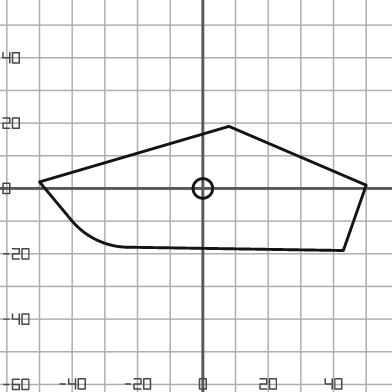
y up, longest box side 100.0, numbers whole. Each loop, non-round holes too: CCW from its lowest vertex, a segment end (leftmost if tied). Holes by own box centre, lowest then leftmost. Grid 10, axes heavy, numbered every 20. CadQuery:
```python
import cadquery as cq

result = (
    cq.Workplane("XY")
    .moveTo(43.0, -19.0)
    .lineTo(50.0, 1.0)
    .lineTo(8.0, 19.0)
    .lineTo(-50.0, 2.0)
    .lineTo(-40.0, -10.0)
    .threePointArc((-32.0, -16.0), (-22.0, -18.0))
    .close()
    .moveTo(0.0, 0.0)
    .circle(3.0)
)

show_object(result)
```